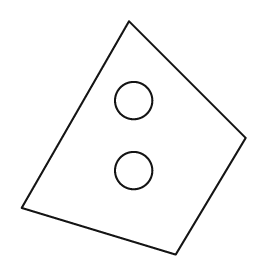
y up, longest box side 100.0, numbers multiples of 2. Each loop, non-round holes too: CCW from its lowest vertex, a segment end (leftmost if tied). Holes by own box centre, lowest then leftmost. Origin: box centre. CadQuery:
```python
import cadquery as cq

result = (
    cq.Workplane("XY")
    .moveTo(18.0, -50.0)
    .lineTo(48.0, 0.0)
    .lineTo(-2.0, 50.0)
    .lineTo(-48.0, -30.0)
    .close()
    .moveTo(0.0, -14.0)
    .circle(8.0)
    .moveTo(0.0, 16.0)
    .circle(8.0)
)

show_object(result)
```